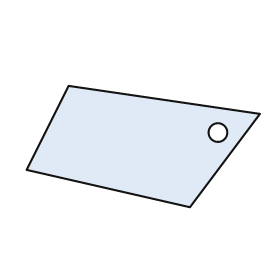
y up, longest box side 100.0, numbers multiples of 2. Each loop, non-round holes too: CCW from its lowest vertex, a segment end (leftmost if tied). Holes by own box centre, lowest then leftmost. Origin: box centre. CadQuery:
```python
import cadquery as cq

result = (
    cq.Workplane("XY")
    .moveTo(20.0, -26.0)
    .lineTo(50.0, 14.0)
    .lineTo(-32.0, 26.0)
    .lineTo(-50.0, -10.0)
    .close()
    .moveTo(32.0, 6.0)
    .circle(4.0)
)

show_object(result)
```